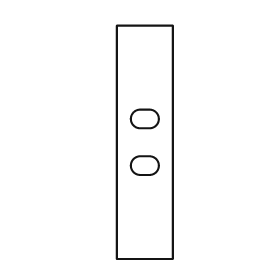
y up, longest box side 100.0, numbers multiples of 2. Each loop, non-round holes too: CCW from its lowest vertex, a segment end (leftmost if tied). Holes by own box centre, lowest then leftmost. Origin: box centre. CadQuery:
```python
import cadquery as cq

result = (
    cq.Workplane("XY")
    .moveTo(-12.0, -50.0)
    .lineTo(12.0, -50.0)
    .lineTo(12.0, 50.0)
    .lineTo(-12.0, 50.0)
    .close()
    .moveTo(-2.0, -14.0)
    .lineTo(2.0, -14.0)
    .threePointArc((6.0, -10.0), (2.0, -6.0))
    .lineTo(-2.0, -6.0)
    .threePointArc((-6.0, -10.0), (-2.0, -14.0))
    .close()
    .moveTo(-2.0, 6.0)
    .lineTo(2.0, 6.0)
    .threePointArc((6.0, 10.0), (2.0, 14.0))
    .lineTo(-2.0, 14.0)
    .threePointArc((-6.0, 10.0), (-2.0, 6.0))
    .close()
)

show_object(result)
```